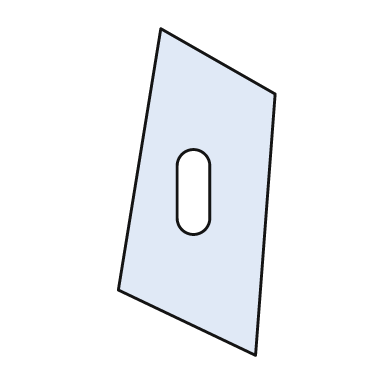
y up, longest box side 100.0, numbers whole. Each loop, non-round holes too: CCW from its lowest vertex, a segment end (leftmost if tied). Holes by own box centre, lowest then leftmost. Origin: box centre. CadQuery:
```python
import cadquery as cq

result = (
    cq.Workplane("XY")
    .moveTo(18.0, -50.0)
    .lineTo(24.0, 30.0)
    .lineTo(-11.0, 50.0)
    .lineTo(-24.0, -30.0)
    .close()
    .moveTo(-6.0, -8.0)
    .threePointArc((-1.0, -13.0), (4.0, -8.0))
    .lineTo(4.0, 8.0)
    .threePointArc((-1.0, 13.0), (-6.0, 8.0))
    .close()
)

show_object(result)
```